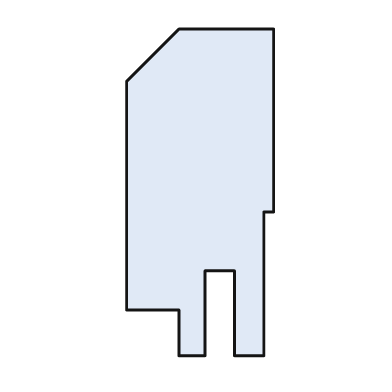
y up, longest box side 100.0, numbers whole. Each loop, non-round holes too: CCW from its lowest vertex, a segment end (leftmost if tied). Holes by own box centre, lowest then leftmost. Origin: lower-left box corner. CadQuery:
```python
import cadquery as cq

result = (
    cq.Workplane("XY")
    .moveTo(16.0, 0.0)
    .lineTo(24.0, 0.0)
    .lineTo(24.0, 26.0)
    .lineTo(33.0, 26.0)
    .lineTo(33.0, 0.0)
    .lineTo(42.0, 0.0)
    .lineTo(42.0, 44.0)
    .lineTo(45.0, 44.0)
    .lineTo(45.0, 100.0)
    .lineTo(16.0, 100.0)
    .lineTo(0.0, 84.0)
    .lineTo(0.0, 14.0)
    .lineTo(16.0, 14.0)
    .close()
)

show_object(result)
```